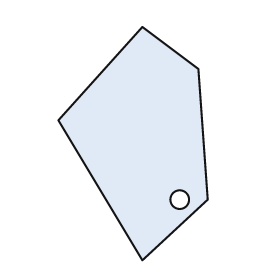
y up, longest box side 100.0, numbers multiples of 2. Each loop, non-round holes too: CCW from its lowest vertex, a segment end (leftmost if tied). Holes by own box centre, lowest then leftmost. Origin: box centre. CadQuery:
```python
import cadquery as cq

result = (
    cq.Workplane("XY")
    .moveTo(4.0, -50.0)
    .lineTo(32.0, -24.0)
    .lineTo(28.0, 32.0)
    .lineTo(4.0, 50.0)
    .lineTo(-32.0, 10.0)
    .close()
    .moveTo(20.0, -24.0)
    .circle(4.0)
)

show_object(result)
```